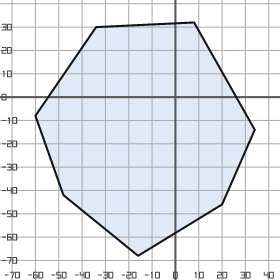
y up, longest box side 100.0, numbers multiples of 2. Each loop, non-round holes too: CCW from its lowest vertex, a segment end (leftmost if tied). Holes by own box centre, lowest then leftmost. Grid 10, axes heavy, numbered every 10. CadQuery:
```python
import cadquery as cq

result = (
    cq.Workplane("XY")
    .moveTo(-16.0, -68.0)
    .lineTo(20.0, -46.0)
    .lineTo(34.0, -14.0)
    .lineTo(8.0, 32.0)
    .lineTo(-34.0, 30.0)
    .lineTo(-60.0, -8.0)
    .lineTo(-48.0, -42.0)
    .close()
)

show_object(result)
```